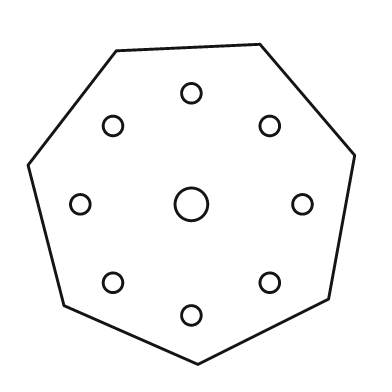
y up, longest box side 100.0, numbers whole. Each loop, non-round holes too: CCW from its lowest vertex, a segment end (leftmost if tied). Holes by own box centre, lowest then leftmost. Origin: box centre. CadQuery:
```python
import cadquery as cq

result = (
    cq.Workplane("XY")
    .moveTo(2.0, -49.0)
    .lineTo(42.0, -29.0)
    .lineTo(50.0, 15.0)
    .lineTo(21.0, 49.0)
    .lineTo(-23.0, 47.0)
    .lineTo(-50.0, 12.0)
    .lineTo(-39.0, -31.0)
    .close()
    .moveTo(0.0, -34.0)
    .circle(3.0)
    .moveTo(-24.0, -24.0)
    .circle(3.0)
    .moveTo(24.0, -24.0)
    .circle(3.0)
    .moveTo(-34.0, 0.0)
    .circle(3.0)
    .moveTo(0.0, 0.0)
    .circle(5.0)
    .moveTo(34.0, 0.0)
    .circle(3.0)
    .moveTo(-24.0, 24.0)
    .circle(3.0)
    .moveTo(24.0, 24.0)
    .circle(3.0)
    .moveTo(0.0, 34.0)
    .circle(3.0)
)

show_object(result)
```